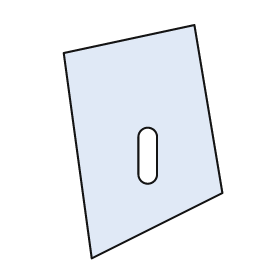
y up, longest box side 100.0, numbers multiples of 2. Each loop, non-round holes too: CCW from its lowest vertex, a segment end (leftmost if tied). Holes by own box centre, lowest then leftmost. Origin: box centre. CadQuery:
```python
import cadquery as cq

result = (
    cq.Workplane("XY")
    .moveTo(-22.0, -50.0)
    .lineTo(34.0, -22.0)
    .lineTo(22.0, 50.0)
    .lineTo(-34.0, 38.0)
    .close()
    .moveTo(-2.0, -14.0)
    .threePointArc((2.0, -18.0), (6.0, -14.0))
    .lineTo(6.0, 2.0)
    .threePointArc((2.0, 6.0), (-2.0, 2.0))
    .close()
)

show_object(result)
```